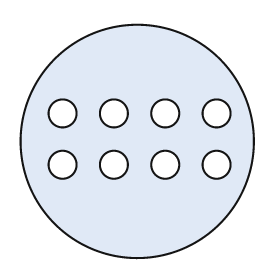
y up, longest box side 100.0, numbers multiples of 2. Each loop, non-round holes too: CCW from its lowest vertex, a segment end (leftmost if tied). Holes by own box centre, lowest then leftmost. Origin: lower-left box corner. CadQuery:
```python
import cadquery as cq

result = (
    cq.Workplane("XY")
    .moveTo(50.0, 50.0)
    .circle(50.0)
    .moveTo(18.0, 40.0)
    .circle(6.0)
    .moveTo(40.0, 40.0)
    .circle(6.0)
    .moveTo(62.0, 40.0)
    .circle(6.0)
    .moveTo(84.0, 40.0)
    .circle(6.0)
    .moveTo(18.0, 62.0)
    .circle(6.0)
    .moveTo(40.0, 62.0)
    .circle(6.0)
    .moveTo(62.0, 62.0)
    .circle(6.0)
    .moveTo(84.0, 62.0)
    .circle(6.0)
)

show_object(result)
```